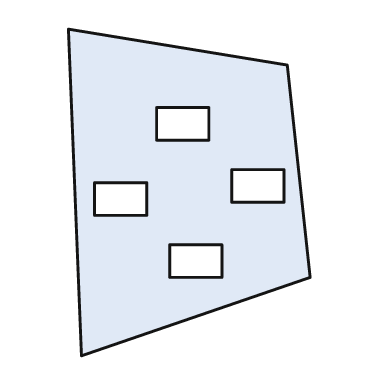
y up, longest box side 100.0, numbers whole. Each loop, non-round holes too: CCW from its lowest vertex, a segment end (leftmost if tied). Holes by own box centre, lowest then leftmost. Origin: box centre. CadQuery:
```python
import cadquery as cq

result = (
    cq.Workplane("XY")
    .moveTo(-33.0, -50.0)
    .lineTo(37.0, -26.0)
    .lineTo(30.0, 39.0)
    .lineTo(-37.0, 50.0)
    .close()
    .moveTo(-6.0, -26.0)
    .lineTo(10.0, -26.0)
    .lineTo(10.0, -16.0)
    .lineTo(-6.0, -16.0)
    .close()
    .moveTo(-29.0, -7.0)
    .lineTo(-13.0, -7.0)
    .lineTo(-13.0, 3.0)
    .lineTo(-29.0, 3.0)
    .close()
    .moveTo(13.0, -3.0)
    .lineTo(29.0, -3.0)
    .lineTo(29.0, 7.0)
    .lineTo(13.0, 7.0)
    .close()
    .moveTo(-10.0, 16.0)
    .lineTo(6.0, 16.0)
    .lineTo(6.0, 26.0)
    .lineTo(-10.0, 26.0)
    .close()
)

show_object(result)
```